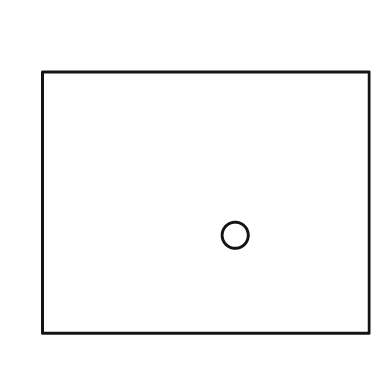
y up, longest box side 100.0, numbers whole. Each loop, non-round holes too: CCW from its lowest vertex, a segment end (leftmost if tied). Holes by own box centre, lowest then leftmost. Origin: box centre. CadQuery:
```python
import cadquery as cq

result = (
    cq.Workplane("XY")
    .moveTo(-50.0, -40.0)
    .lineTo(50.0, -40.0)
    .lineTo(50.0, 40.0)
    .lineTo(-50.0, 40.0)
    .close()
    .moveTo(9.0, -10.0)
    .circle(4.0)
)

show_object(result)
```